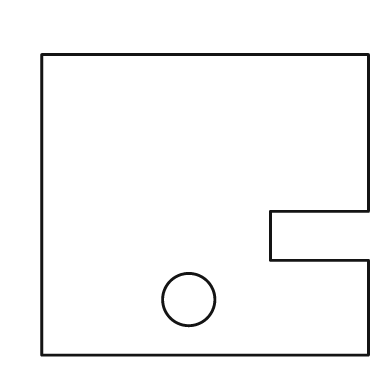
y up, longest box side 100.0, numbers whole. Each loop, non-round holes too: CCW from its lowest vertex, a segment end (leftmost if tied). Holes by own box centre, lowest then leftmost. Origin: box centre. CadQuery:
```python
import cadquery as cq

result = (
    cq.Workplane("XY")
    .moveTo(-50.0, -46.0)
    .lineTo(50.0, -46.0)
    .lineTo(50.0, -17.0)
    .lineTo(20.0, -17.0)
    .lineTo(20.0, -2.0)
    .lineTo(50.0, -2.0)
    .lineTo(50.0, 46.0)
    .lineTo(-50.0, 46.0)
    .close()
    .moveTo(-5.0, -29.0)
    .circle(8.0)
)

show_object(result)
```